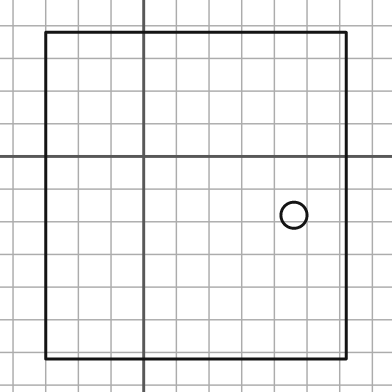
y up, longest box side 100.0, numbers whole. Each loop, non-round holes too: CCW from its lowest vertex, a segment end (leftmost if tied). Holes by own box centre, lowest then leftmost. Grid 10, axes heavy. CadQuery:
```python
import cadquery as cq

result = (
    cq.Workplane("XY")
    .moveTo(-30.0, -62.0)
    .lineTo(62.0, -62.0)
    .lineTo(62.0, 38.0)
    .lineTo(-30.0, 38.0)
    .close()
    .moveTo(46.0, -18.0)
    .circle(4.0)
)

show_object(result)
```